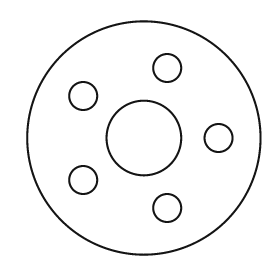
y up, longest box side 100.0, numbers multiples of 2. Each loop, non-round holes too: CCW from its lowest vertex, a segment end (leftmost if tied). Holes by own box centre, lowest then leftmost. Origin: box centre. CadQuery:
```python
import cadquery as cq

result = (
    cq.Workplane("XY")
    .moveTo(0.0, 0.0)
    .circle(50.0)
    .moveTo(10.0, -30.0)
    .circle(6.0)
    .moveTo(-26.0, -18.0)
    .circle(6.0)
    .moveTo(0.0, 0.0)
    .circle(16.0)
    .moveTo(32.0, 0.0)
    .circle(6.0)
    .moveTo(-26.0, 18.0)
    .circle(6.0)
    .moveTo(10.0, 30.0)
    .circle(6.0)
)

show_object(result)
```